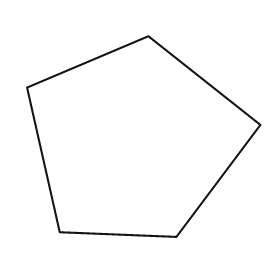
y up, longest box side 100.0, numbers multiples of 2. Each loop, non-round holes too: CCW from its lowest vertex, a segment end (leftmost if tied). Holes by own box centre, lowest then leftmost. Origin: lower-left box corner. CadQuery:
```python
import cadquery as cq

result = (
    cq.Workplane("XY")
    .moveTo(64.0, 0.0)
    .lineTo(100.0, 48.0)
    .lineTo(52.0, 86.0)
    .lineTo(0.0, 64.0)
    .lineTo(14.0, 2.0)
    .close()
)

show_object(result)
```